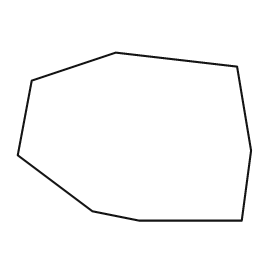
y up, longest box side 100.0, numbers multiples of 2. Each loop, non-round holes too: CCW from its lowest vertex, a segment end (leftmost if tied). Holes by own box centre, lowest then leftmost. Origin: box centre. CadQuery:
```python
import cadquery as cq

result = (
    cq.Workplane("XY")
    .moveTo(2.0, -36.0)
    .lineTo(46.0, -36.0)
    .lineTo(50.0, -6.0)
    .lineTo(44.0, 30.0)
    .lineTo(-8.0, 36.0)
    .lineTo(-44.0, 24.0)
    .lineTo(-50.0, -8.0)
    .lineTo(-18.0, -32.0)
    .close()
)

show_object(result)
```